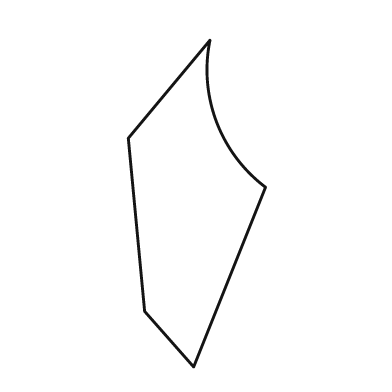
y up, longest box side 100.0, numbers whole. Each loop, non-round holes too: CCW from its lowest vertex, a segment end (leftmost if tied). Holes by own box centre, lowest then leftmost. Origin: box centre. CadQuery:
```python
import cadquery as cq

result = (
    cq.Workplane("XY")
    .moveTo(-1.0, -50.0)
    .lineTo(21.0, 5.0)
    .threePointArc((6.0, 25.0), (4.0, 50.0))
    .lineTo(-21.0, 20.0)
    .lineTo(-16.0, -33.0)
    .close()
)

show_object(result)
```